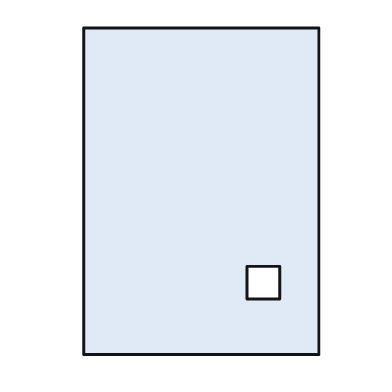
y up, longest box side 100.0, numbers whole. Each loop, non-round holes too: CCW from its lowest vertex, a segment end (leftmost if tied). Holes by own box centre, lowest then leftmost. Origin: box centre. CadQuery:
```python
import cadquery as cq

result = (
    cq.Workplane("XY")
    .moveTo(-36.0, -50.0)
    .lineTo(36.0, -50.0)
    .lineTo(36.0, 50.0)
    .lineTo(-36.0, 50.0)
    .close()
    .moveTo(14.0, -33.0)
    .lineTo(24.0, -33.0)
    .lineTo(24.0, -23.0)
    .lineTo(14.0, -23.0)
    .close()
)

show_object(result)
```